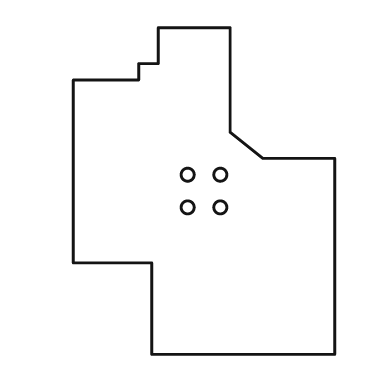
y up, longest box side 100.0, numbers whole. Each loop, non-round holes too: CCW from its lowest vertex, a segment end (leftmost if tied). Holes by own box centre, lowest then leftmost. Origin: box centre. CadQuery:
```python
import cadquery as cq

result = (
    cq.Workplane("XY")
    .moveTo(-16.0, -50.0)
    .lineTo(40.0, -50.0)
    .lineTo(40.0, 10.0)
    .lineTo(18.0, 10.0)
    .lineTo(8.0, 18.0)
    .lineTo(8.0, 50.0)
    .lineTo(-14.0, 50.0)
    .lineTo(-14.0, 39.0)
    .lineTo(-20.0, 39.0)
    .lineTo(-20.0, 34.0)
    .lineTo(-40.0, 34.0)
    .lineTo(-40.0, -22.0)
    .lineTo(-16.0, -22.0)
    .close()
    .moveTo(-5.0, -5.0)
    .circle(2.0)
    .moveTo(5.0, -5.0)
    .circle(2.0)
    .moveTo(-5.0, 5.0)
    .circle(2.0)
    .moveTo(5.0, 5.0)
    .circle(2.0)
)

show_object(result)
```